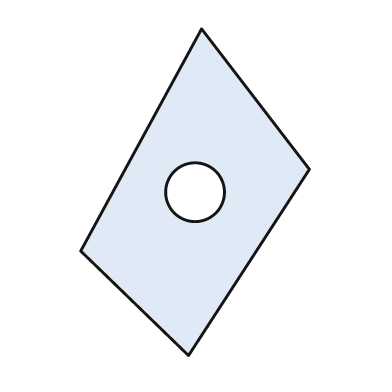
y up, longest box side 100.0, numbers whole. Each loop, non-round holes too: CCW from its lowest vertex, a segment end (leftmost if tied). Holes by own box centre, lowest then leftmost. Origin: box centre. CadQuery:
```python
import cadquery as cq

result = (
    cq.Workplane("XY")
    .moveTo(-2.0, -50.0)
    .lineTo(35.0, 7.0)
    .lineTo(2.0, 50.0)
    .lineTo(-35.0, -18.0)
    .close()
    .moveTo(0.0, 0.0)
    .circle(9.0)
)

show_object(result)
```